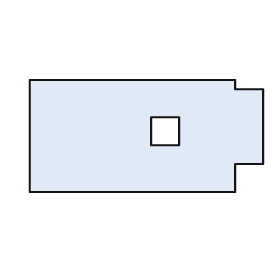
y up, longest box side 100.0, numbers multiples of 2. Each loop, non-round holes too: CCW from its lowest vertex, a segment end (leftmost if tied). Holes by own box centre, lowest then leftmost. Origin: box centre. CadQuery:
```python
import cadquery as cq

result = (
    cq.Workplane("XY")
    .moveTo(-50.0, -24.0)
    .lineTo(38.0, -24.0)
    .lineTo(38.0, -12.0)
    .lineTo(50.0, -12.0)
    .lineTo(50.0, 20.0)
    .lineTo(38.0, 20.0)
    .lineTo(38.0, 24.0)
    .lineTo(-50.0, 24.0)
    .close()
    .moveTo(2.0, -4.0)
    .lineTo(14.0, -4.0)
    .lineTo(14.0, 8.0)
    .lineTo(2.0, 8.0)
    .close()
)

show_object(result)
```